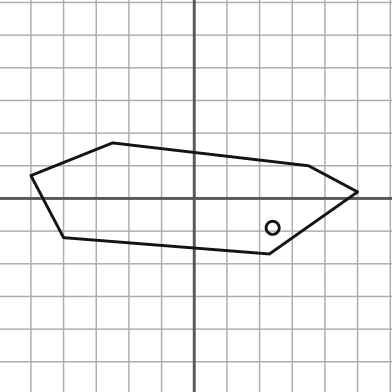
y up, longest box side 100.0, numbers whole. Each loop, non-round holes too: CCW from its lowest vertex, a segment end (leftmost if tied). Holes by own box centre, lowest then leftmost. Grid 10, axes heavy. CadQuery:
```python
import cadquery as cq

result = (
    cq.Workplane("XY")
    .moveTo(23.0, -17.0)
    .lineTo(50.0, 2.0)
    .lineTo(35.0, 10.0)
    .lineTo(-25.0, 17.0)
    .lineTo(-50.0, 7.0)
    .lineTo(-40.0, -12.0)
    .close()
    .moveTo(24.0, -9.0)
    .circle(2.0)
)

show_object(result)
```